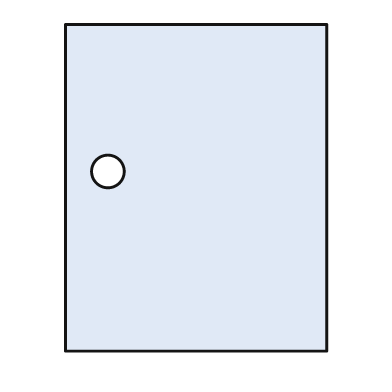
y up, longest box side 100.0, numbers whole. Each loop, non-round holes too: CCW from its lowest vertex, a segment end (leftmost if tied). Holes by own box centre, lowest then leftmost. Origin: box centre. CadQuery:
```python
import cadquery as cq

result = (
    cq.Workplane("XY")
    .moveTo(-40.0, -50.0)
    .lineTo(40.0, -50.0)
    .lineTo(40.0, 50.0)
    .lineTo(-40.0, 50.0)
    .close()
    .moveTo(-27.0, 5.0)
    .circle(5.0)
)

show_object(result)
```